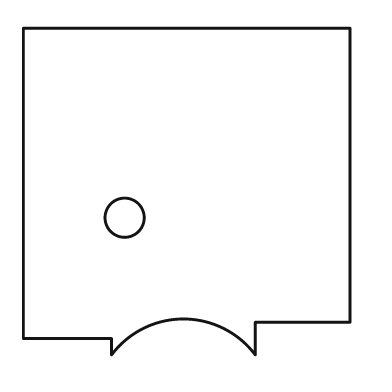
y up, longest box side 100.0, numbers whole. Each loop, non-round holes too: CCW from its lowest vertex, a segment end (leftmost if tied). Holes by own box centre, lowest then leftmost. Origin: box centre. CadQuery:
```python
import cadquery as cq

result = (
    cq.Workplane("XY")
    .moveTo(-23.0, -50.0)
    .threePointArc((-1.0, -39.0), (21.0, -50.0))
    .lineTo(21.0, -40.0)
    .lineTo(50.0, -40.0)
    .lineTo(50.0, 50.0)
    .lineTo(-50.0, 50.0)
    .lineTo(-50.0, -45.0)
    .lineTo(-23.0, -45.0)
    .close()
    .moveTo(-19.0, -8.0)
    .circle(6.0)
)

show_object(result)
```